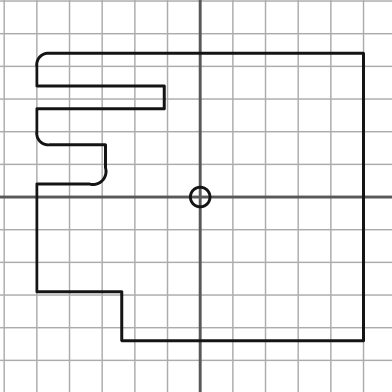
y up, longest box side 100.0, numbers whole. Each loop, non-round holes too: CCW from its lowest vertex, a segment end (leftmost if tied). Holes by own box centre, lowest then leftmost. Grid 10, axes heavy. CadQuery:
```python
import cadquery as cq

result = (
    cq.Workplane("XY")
    .moveTo(-24.0, -44.0)
    .lineTo(50.0, -44.0)
    .lineTo(50.0, 44.0)
    .lineTo(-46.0, 44.0)
    .threePointArc((-49.0, 43.0), (-50.0, 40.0))
    .lineTo(-50.0, 34.0)
    .lineTo(-11.0, 34.0)
    .lineTo(-11.0, 27.0)
    .lineTo(-50.0, 27.0)
    .lineTo(-50.0, 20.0)
    .threePointArc((-49.0, 17.0), (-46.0, 16.0))
    .lineTo(-29.0, 16.0)
    .lineTo(-29.0, 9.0)
    .threePointArc((-30.0, 5.0), (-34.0, 4.0))
    .lineTo(-50.0, 4.0)
    .lineTo(-50.0, -29.0)
    .lineTo(-24.0, -29.0)
    .close()
    .moveTo(0.0, 0.0)
    .circle(3.0)
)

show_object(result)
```